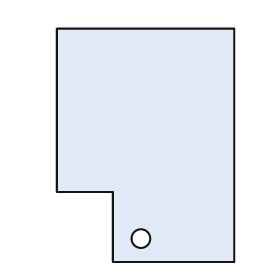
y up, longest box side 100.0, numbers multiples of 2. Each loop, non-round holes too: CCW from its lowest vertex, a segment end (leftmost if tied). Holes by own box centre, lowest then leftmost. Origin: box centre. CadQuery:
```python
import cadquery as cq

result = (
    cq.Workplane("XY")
    .moveTo(-14.0, -50.0)
    .lineTo(38.0, -50.0)
    .lineTo(38.0, 50.0)
    .lineTo(-38.0, 50.0)
    .lineTo(-38.0, -20.0)
    .lineTo(-14.0, -20.0)
    .close()
    .moveTo(-2.0, -40.0)
    .circle(4.0)
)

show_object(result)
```